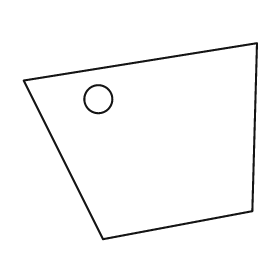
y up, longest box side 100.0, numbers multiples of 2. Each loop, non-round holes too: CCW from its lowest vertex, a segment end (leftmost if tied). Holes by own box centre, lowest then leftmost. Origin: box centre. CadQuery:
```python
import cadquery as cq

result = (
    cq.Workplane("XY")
    .moveTo(-16.0, -42.0)
    .lineTo(48.0, -30.0)
    .lineTo(50.0, 42.0)
    .lineTo(-50.0, 26.0)
    .close()
    .moveTo(-18.0, 18.0)
    .circle(6.0)
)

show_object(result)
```